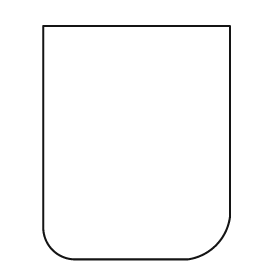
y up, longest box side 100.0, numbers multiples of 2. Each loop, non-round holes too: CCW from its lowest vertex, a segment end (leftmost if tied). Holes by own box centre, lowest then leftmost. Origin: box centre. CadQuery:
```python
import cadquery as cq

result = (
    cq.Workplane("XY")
    .moveTo(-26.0, -50.0)
    .lineTo(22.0, -50.0)
    .threePointArc((34.0, -44.0), (40.0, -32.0))
    .lineTo(40.0, 50.0)
    .lineTo(-40.0, 50.0)
    .lineTo(-40.0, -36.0)
    .threePointArc((-36.0, -46.0), (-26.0, -50.0))
    .close()
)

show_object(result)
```